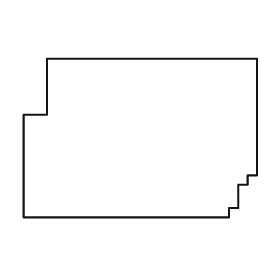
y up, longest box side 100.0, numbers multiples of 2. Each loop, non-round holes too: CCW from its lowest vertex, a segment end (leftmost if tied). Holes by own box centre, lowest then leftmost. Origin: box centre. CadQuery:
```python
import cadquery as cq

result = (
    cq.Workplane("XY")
    .moveTo(-50.0, -34.0)
    .lineTo(38.0, -34.0)
    .lineTo(38.0, -30.0)
    .lineTo(42.0, -30.0)
    .lineTo(42.0, -20.0)
    .lineTo(46.0, -20.0)
    .lineTo(46.0, -16.0)
    .lineTo(50.0, -16.0)
    .lineTo(50.0, 34.0)
    .lineTo(-40.0, 34.0)
    .lineTo(-40.0, 10.0)
    .lineTo(-50.0, 10.0)
    .close()
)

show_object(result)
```